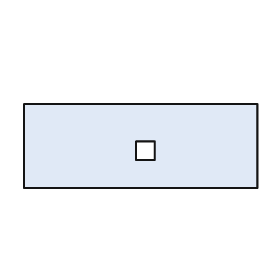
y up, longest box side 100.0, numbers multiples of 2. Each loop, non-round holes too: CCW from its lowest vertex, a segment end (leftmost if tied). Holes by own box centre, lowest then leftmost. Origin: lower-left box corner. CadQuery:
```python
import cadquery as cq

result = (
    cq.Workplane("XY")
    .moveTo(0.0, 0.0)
    .lineTo(100.0, 0.0)
    .lineTo(100.0, 36.0)
    .lineTo(0.0, 36.0)
    .close()
    .moveTo(48.0, 12.0)
    .lineTo(56.0, 12.0)
    .lineTo(56.0, 20.0)
    .lineTo(48.0, 20.0)
    .close()
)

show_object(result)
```